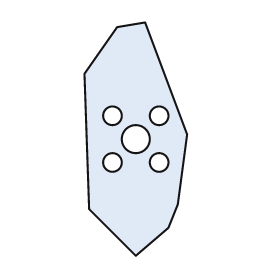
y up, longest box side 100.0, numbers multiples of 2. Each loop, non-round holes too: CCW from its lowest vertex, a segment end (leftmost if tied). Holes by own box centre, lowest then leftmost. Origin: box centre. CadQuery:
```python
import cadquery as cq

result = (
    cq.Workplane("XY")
    .moveTo(0.0, -50.0)
    .lineTo(14.0, -38.0)
    .lineTo(18.0, -28.0)
    .lineTo(22.0, 2.0)
    .lineTo(4.0, 50.0)
    .lineTo(-8.0, 48.0)
    .lineTo(-22.0, 28.0)
    .lineTo(-20.0, -30.0)
    .close()
    .moveTo(-10.0, -10.0)
    .circle(4.0)
    .moveTo(10.0, -10.0)
    .circle(4.0)
    .moveTo(0.0, 0.0)
    .circle(6.0)
    .moveTo(-10.0, 10.0)
    .circle(4.0)
    .moveTo(10.0, 10.0)
    .circle(4.0)
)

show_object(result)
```